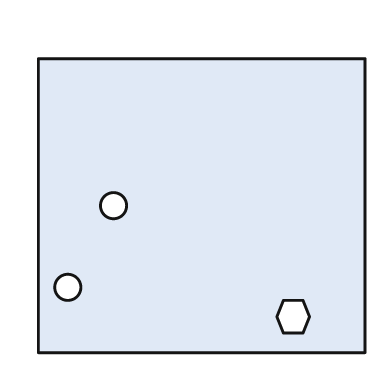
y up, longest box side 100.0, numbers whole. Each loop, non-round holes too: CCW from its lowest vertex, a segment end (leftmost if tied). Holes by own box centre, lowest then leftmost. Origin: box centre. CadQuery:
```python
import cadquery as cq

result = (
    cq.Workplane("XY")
    .moveTo(-50.0, -45.0)
    .lineTo(50.0, -45.0)
    .lineTo(50.0, 45.0)
    .lineTo(-50.0, 45.0)
    .close()
    .moveTo(25.0, -39.0)
    .lineTo(31.0, -39.0)
    .lineTo(33.0, -34.0)
    .lineTo(31.0, -29.0)
    .lineTo(25.0, -29.0)
    .lineTo(23.0, -34.0)
    .close()
    .moveTo(-41.0, -25.0)
    .circle(4.0)
    .moveTo(-27.0, 0.0)
    .circle(4.0)
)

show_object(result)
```